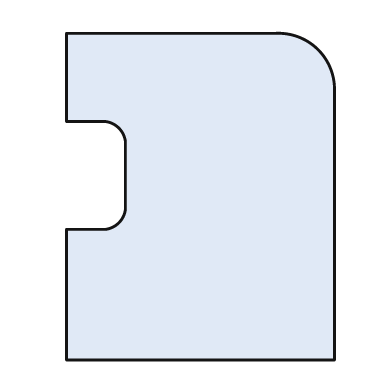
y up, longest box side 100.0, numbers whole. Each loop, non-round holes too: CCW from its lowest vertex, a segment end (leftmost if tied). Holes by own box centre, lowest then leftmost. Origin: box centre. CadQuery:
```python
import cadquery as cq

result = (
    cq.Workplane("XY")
    .moveTo(-41.0, -50.0)
    .lineTo(41.0, -50.0)
    .lineTo(41.0, 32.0)
    .threePointArc((36.0, 45.0), (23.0, 50.0))
    .lineTo(-41.0, 50.0)
    .lineTo(-41.0, 23.0)
    .lineTo(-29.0, 23.0)
    .threePointArc((-25.0, 21.0), (-23.0, 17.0))
    .lineTo(-23.0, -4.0)
    .threePointArc((-25.0, -8.0), (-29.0, -10.0))
    .lineTo(-41.0, -10.0)
    .close()
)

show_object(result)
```